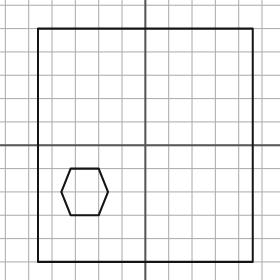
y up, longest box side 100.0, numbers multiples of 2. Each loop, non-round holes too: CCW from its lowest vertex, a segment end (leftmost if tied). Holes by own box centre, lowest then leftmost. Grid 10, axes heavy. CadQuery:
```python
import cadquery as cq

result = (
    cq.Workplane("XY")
    .moveTo(-46.0, -50.0)
    .lineTo(46.0, -50.0)
    .lineTo(46.0, 50.0)
    .lineTo(-46.0, 50.0)
    .close()
    .moveTo(-32.0, -30.0)
    .lineTo(-20.0, -30.0)
    .lineTo(-16.0, -20.0)
    .lineTo(-20.0, -10.0)
    .lineTo(-32.0, -10.0)
    .lineTo(-36.0, -20.0)
    .close()
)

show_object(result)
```